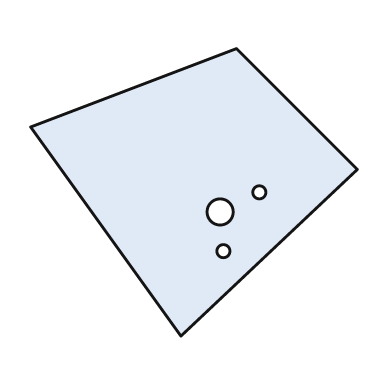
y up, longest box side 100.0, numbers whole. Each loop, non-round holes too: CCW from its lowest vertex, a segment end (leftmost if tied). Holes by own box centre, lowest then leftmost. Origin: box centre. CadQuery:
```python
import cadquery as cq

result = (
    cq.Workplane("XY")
    .moveTo(-4.0, -44.0)
    .lineTo(50.0, 7.0)
    .lineTo(13.0, 44.0)
    .lineTo(-50.0, 20.0)
    .close()
    .moveTo(9.0, -18.0)
    .circle(2.0)
    .moveTo(8.0, -6.0)
    .circle(4.0)
    .moveTo(20.0, 0.0)
    .circle(2.0)
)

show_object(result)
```